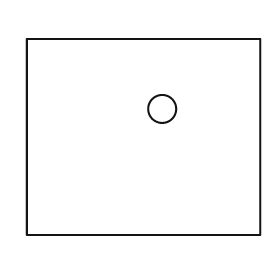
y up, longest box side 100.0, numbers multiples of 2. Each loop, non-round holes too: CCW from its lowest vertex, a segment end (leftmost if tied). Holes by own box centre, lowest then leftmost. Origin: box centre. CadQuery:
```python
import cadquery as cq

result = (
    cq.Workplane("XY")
    .moveTo(-50.0, -42.0)
    .lineTo(50.0, -42.0)
    .lineTo(50.0, 42.0)
    .lineTo(-50.0, 42.0)
    .close()
    .moveTo(8.0, 12.0)
    .circle(6.0)
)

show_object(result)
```